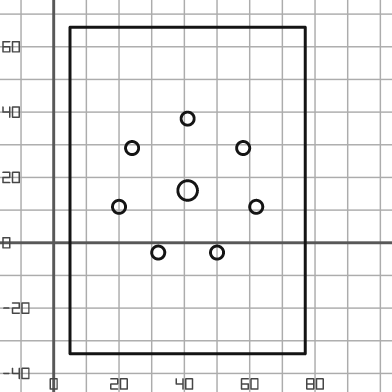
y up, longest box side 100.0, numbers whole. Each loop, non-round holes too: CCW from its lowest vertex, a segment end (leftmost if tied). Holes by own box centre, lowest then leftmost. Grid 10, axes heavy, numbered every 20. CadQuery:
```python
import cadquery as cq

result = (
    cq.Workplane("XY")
    .moveTo(5.0, -34.0)
    .lineTo(77.0, -34.0)
    .lineTo(77.0, 66.0)
    .lineTo(5.0, 66.0)
    .close()
    .moveTo(32.0, -3.0)
    .circle(2.0)
    .moveTo(50.0, -3.0)
    .circle(2.0)
    .moveTo(20.0, 11.0)
    .circle(2.0)
    .moveTo(62.0, 11.0)
    .circle(2.0)
    .moveTo(41.0, 16.0)
    .circle(3.0)
    .moveTo(24.0, 29.0)
    .circle(2.0)
    .moveTo(58.0, 29.0)
    .circle(2.0)
    .moveTo(41.0, 38.0)
    .circle(2.0)
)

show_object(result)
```